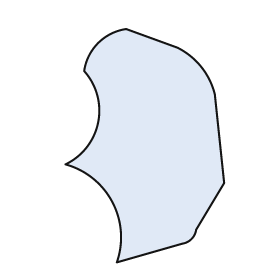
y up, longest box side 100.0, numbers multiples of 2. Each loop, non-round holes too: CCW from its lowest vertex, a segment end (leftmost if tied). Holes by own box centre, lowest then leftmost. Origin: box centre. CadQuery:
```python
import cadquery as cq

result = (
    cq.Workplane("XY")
    .moveTo(-12.0, -50.0)
    .lineTo(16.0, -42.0)
    .threePointArc((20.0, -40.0), (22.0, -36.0))
    .lineTo(34.0, -16.0)
    .lineTo(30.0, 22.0)
    .threePointArc((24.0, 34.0), (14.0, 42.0))
    .lineTo(-8.0, 50.0)
    .threePointArc((-20.0, 44.0), (-26.0, 32.0))
    .threePointArc((-20.0, 10.0), (-34.0, -8.0))
    .threePointArc((-14.0, -24.0), (-12.0, -50.0))
    .close()
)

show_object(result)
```